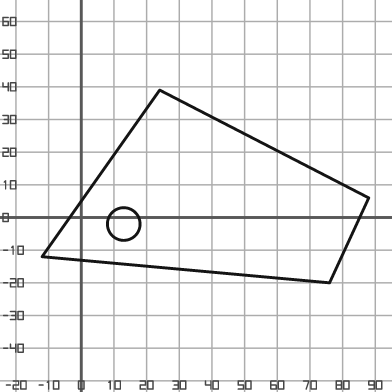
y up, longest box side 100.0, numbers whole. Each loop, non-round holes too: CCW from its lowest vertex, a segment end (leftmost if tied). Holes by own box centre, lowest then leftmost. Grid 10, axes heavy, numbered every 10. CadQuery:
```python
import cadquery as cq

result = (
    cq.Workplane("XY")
    .moveTo(76.0, -20.0)
    .lineTo(88.0, 6.0)
    .lineTo(24.0, 39.0)
    .lineTo(-12.0, -12.0)
    .close()
    .moveTo(13.0, -2.0)
    .circle(5.0)
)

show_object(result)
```